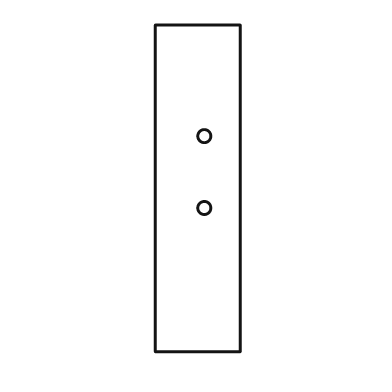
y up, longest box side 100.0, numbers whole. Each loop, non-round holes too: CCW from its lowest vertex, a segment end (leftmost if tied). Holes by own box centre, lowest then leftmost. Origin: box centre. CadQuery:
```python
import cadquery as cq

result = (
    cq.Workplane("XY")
    .moveTo(-13.0, -50.0)
    .lineTo(13.0, -50.0)
    .lineTo(13.0, 50.0)
    .lineTo(-13.0, 50.0)
    .close()
    .moveTo(2.0, -6.0)
    .circle(2.0)
    .moveTo(2.0, 16.0)
    .circle(2.0)
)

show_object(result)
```